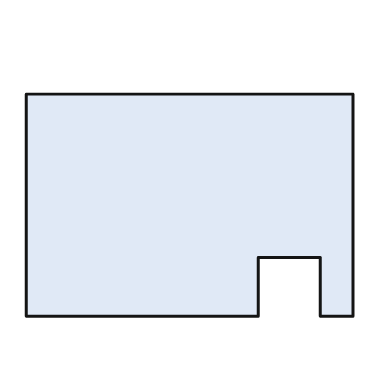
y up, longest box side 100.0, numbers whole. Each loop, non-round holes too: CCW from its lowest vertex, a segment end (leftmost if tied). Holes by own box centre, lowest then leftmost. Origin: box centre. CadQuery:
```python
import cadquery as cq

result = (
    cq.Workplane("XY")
    .moveTo(-50.0, -34.0)
    .lineTo(21.0, -34.0)
    .lineTo(21.0, -16.0)
    .lineTo(40.0, -16.0)
    .lineTo(40.0, -34.0)
    .lineTo(50.0, -34.0)
    .lineTo(50.0, 34.0)
    .lineTo(-50.0, 34.0)
    .close()
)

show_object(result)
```